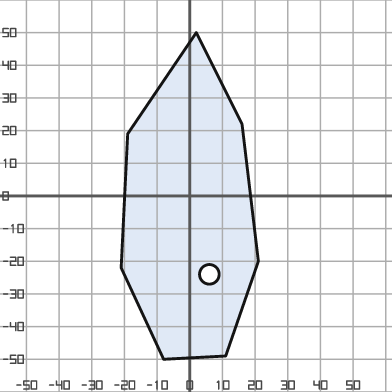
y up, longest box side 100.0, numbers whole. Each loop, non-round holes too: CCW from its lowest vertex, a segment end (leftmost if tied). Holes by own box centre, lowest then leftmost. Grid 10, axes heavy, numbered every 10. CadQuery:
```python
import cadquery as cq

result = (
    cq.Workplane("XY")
    .moveTo(-8.0, -50.0)
    .lineTo(11.0, -49.0)
    .lineTo(21.0, -20.0)
    .lineTo(16.0, 22.0)
    .lineTo(2.0, 50.0)
    .lineTo(-19.0, 19.0)
    .lineTo(-21.0, -22.0)
    .close()
    .moveTo(6.0, -24.0)
    .circle(3.0)
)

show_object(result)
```